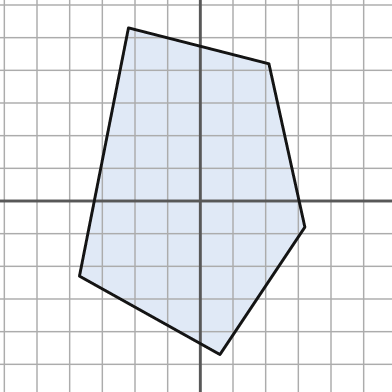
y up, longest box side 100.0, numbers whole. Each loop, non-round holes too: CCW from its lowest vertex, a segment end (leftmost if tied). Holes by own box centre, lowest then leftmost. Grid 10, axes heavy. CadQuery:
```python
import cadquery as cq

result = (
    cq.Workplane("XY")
    .moveTo(6.0, -47.0)
    .lineTo(32.0, -8.0)
    .lineTo(21.0, 42.0)
    .lineTo(-22.0, 53.0)
    .lineTo(-37.0, -23.0)
    .close()
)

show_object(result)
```